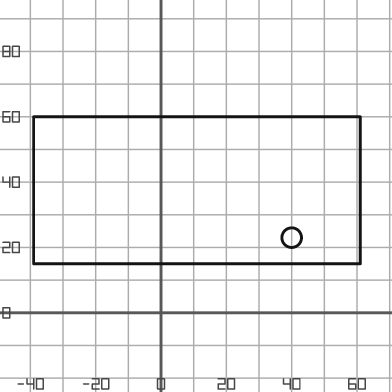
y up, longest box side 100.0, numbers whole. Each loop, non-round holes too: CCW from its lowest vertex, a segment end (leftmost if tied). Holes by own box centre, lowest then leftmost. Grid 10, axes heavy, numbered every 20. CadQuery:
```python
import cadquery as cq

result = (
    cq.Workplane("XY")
    .moveTo(-39.0, 15.0)
    .lineTo(61.0, 15.0)
    .lineTo(61.0, 60.0)
    .lineTo(-39.0, 60.0)
    .close()
    .moveTo(40.0, 23.0)
    .circle(3.0)
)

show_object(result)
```